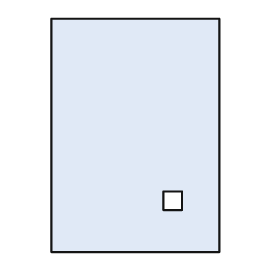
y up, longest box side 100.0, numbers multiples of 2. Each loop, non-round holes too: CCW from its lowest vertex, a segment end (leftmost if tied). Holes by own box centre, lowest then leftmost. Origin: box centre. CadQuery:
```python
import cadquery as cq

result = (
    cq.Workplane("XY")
    .moveTo(-36.0, -50.0)
    .lineTo(36.0, -50.0)
    .lineTo(36.0, 50.0)
    .lineTo(-36.0, 50.0)
    .close()
    .moveTo(12.0, -32.0)
    .lineTo(20.0, -32.0)
    .lineTo(20.0, -24.0)
    .lineTo(12.0, -24.0)
    .close()
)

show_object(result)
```